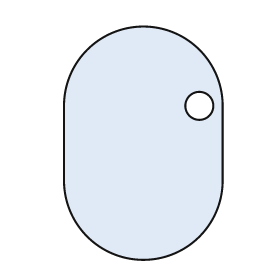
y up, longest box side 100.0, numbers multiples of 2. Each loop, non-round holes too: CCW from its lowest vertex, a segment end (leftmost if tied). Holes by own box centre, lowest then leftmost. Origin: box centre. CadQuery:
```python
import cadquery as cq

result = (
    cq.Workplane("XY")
    .moveTo(-34.0, -16.0)
    .threePointArc((0.0, -50.0), (34.0, -16.0))
    .lineTo(34.0, 16.0)
    .threePointArc((0.0, 50.0), (-34.0, 16.0))
    .close()
    .moveTo(24.0, 16.0)
    .circle(6.0)
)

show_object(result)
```